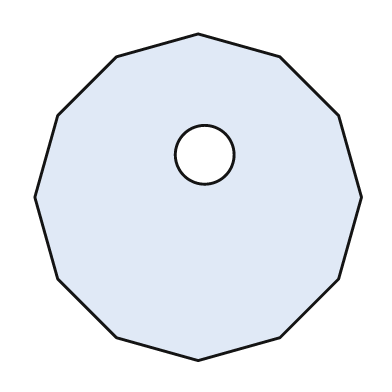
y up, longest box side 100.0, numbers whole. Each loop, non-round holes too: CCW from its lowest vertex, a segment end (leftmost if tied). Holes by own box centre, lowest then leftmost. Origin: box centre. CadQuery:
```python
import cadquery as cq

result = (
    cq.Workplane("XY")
    .moveTo(0.0, -50.0)
    .lineTo(25.0, -43.0)
    .lineTo(43.0, -25.0)
    .lineTo(50.0, 0.0)
    .lineTo(43.0, 25.0)
    .lineTo(25.0, 43.0)
    .lineTo(0.0, 50.0)
    .lineTo(-25.0, 43.0)
    .lineTo(-43.0, 25.0)
    .lineTo(-50.0, 0.0)
    .lineTo(-43.0, -25.0)
    .lineTo(-25.0, -43.0)
    .close()
    .moveTo(2.0, 13.0)
    .circle(9.0)
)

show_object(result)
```